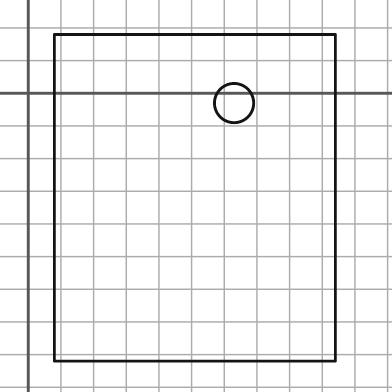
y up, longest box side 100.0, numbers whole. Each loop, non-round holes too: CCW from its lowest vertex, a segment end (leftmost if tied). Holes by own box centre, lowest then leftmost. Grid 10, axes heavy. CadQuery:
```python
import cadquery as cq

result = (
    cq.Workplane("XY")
    .moveTo(8.0, -82.0)
    .lineTo(94.0, -82.0)
    .lineTo(94.0, 18.0)
    .lineTo(8.0, 18.0)
    .close()
    .moveTo(63.0, -3.0)
    .circle(6.0)
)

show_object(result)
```